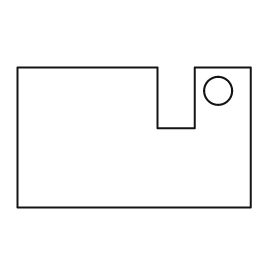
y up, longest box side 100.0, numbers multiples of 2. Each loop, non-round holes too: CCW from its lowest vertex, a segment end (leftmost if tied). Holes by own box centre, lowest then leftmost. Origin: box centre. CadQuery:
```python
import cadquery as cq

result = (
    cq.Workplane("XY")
    .moveTo(-50.0, -30.0)
    .lineTo(50.0, -30.0)
    .lineTo(50.0, 30.0)
    .lineTo(26.0, 30.0)
    .lineTo(26.0, 4.0)
    .lineTo(10.0, 4.0)
    .lineTo(10.0, 30.0)
    .lineTo(-50.0, 30.0)
    .close()
    .moveTo(36.0, 20.0)
    .circle(6.0)
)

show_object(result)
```